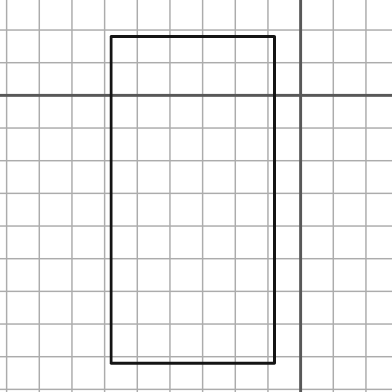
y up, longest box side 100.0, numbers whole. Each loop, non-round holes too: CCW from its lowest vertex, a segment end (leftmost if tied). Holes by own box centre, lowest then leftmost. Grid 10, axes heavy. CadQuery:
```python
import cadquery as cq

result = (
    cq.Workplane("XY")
    .moveTo(-58.0, -82.0)
    .lineTo(-8.0, -82.0)
    .lineTo(-8.0, 18.0)
    .lineTo(-58.0, 18.0)
    .close()
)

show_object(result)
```